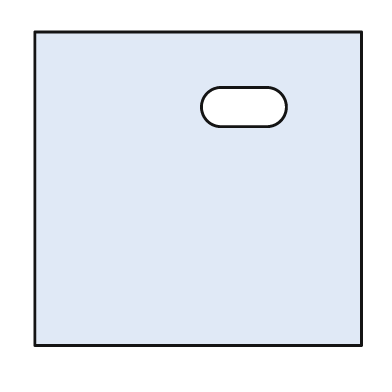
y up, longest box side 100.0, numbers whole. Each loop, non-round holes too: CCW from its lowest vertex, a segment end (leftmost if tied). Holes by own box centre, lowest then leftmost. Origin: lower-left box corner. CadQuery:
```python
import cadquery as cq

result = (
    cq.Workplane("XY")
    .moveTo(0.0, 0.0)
    .lineTo(100.0, 0.0)
    .lineTo(100.0, 96.0)
    .lineTo(0.0, 96.0)
    .close()
    .moveTo(57.0, 67.0)
    .lineTo(71.0, 67.0)
    .threePointArc((77.0, 73.0), (71.0, 79.0))
    .lineTo(57.0, 79.0)
    .threePointArc((51.0, 73.0), (57.0, 67.0))
    .close()
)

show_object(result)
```